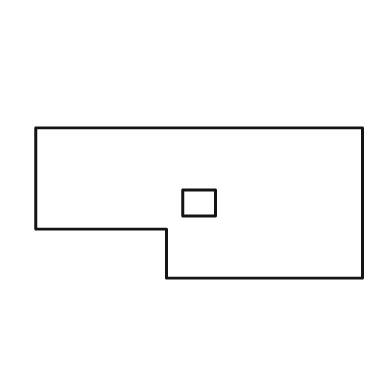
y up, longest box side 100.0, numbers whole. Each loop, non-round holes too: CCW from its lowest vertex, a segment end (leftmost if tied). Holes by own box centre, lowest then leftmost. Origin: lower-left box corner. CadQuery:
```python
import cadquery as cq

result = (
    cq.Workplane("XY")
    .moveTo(40.0, 0.0)
    .lineTo(100.0, 0.0)
    .lineTo(100.0, 46.0)
    .lineTo(0.0, 46.0)
    .lineTo(0.0, 15.0)
    .lineTo(40.0, 15.0)
    .close()
    .moveTo(45.0, 19.0)
    .lineTo(55.0, 19.0)
    .lineTo(55.0, 27.0)
    .lineTo(45.0, 27.0)
    .close()
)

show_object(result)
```